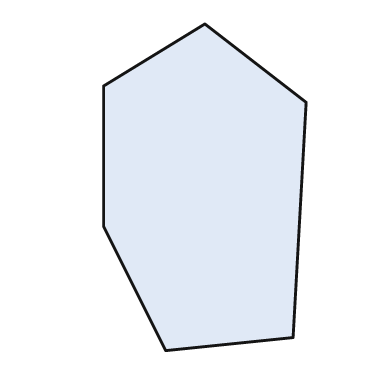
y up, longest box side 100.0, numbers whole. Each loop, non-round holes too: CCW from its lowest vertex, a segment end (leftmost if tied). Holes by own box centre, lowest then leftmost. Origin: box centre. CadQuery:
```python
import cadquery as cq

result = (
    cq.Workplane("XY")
    .moveTo(-12.0, -50.0)
    .lineTo(27.0, -46.0)
    .lineTo(31.0, 26.0)
    .lineTo(0.0, 50.0)
    .lineTo(-31.0, 31.0)
    .lineTo(-31.0, -12.0)
    .close()
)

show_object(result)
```